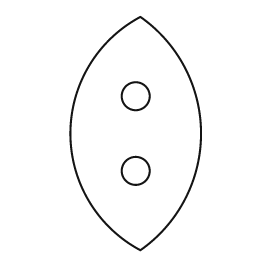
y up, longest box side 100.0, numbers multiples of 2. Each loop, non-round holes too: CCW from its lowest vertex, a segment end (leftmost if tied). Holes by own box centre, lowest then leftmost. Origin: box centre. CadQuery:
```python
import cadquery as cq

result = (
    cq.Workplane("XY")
    .moveTo(2.0, -50.0)
    .threePointArc((28.0, 0.0), (2.0, 50.0))
    .threePointArc((-28.0, 0.0), (2.0, -50.0))
    .close()
    .moveTo(0.0, -16.0)
    .circle(6.0)
    .moveTo(0.0, 16.0)
    .circle(6.0)
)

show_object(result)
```